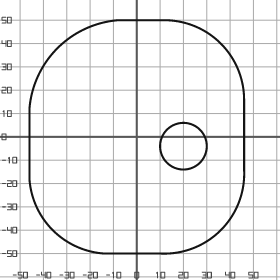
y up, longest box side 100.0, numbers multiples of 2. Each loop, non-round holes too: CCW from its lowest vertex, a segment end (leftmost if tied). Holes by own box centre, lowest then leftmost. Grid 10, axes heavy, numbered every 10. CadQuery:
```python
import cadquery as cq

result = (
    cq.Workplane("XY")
    .moveTo(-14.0, -50.0)
    .lineTo(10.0, -50.0)
    .threePointArc((36.0, -40.0), (46.0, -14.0))
    .lineTo(46.0, 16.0)
    .threePointArc((36.0, 40.0), (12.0, 50.0))
    .lineTo(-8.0, 50.0)
    .threePointArc((-34.0, 38.0), (-46.0, 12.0))
    .lineTo(-46.0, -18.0)
    .threePointArc((-36.0, -40.0), (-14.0, -50.0))
    .close()
    .moveTo(20.0, -4.0)
    .circle(10.0)
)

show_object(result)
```